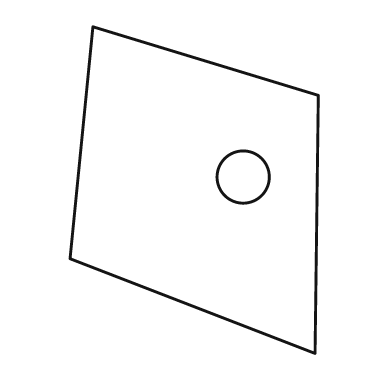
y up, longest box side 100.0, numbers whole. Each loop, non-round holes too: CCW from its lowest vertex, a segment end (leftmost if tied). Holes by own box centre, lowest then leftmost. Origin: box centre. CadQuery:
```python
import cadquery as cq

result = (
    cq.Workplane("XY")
    .moveTo(37.0, -50.0)
    .lineTo(38.0, 29.0)
    .lineTo(-31.0, 50.0)
    .lineTo(-38.0, -21.0)
    .close()
    .moveTo(15.0, 4.0)
    .circle(8.0)
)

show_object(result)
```